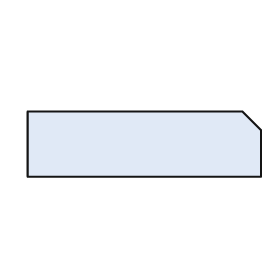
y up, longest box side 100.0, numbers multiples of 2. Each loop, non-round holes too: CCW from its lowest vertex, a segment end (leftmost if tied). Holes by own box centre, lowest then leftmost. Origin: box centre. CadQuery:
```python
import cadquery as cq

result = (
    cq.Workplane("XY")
    .moveTo(-50.0, -14.0)
    .lineTo(50.0, -14.0)
    .lineTo(50.0, 6.0)
    .lineTo(42.0, 14.0)
    .lineTo(-50.0, 14.0)
    .close()
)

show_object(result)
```